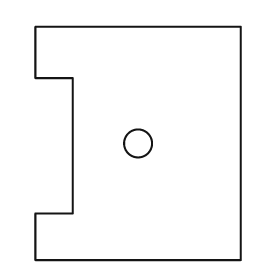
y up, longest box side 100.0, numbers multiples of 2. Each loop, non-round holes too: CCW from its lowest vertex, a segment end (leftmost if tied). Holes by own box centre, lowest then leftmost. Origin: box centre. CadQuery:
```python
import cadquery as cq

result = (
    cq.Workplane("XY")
    .moveTo(-44.0, -50.0)
    .lineTo(44.0, -50.0)
    .lineTo(44.0, 50.0)
    .lineTo(-44.0, 50.0)
    .lineTo(-44.0, 28.0)
    .lineTo(-28.0, 28.0)
    .lineTo(-28.0, -30.0)
    .lineTo(-44.0, -30.0)
    .close()
    .moveTo(0.0, 0.0)
    .circle(6.0)
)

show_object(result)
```